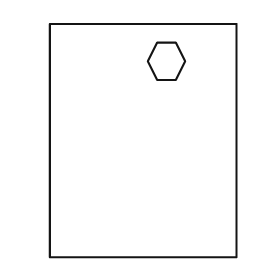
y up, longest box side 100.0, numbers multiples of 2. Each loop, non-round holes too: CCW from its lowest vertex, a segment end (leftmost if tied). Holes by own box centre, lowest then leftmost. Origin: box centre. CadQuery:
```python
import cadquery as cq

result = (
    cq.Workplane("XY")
    .moveTo(-40.0, -50.0)
    .lineTo(40.0, -50.0)
    .lineTo(40.0, 50.0)
    .lineTo(-40.0, 50.0)
    .close()
    .moveTo(6.0, 26.0)
    .lineTo(14.0, 26.0)
    .lineTo(18.0, 34.0)
    .lineTo(14.0, 42.0)
    .lineTo(6.0, 42.0)
    .lineTo(2.0, 34.0)
    .close()
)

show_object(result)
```